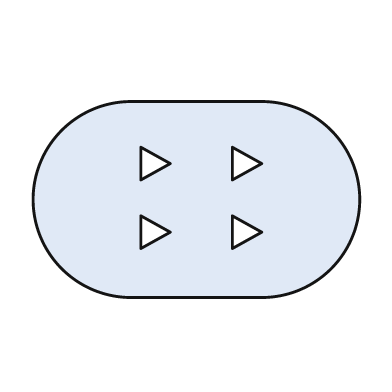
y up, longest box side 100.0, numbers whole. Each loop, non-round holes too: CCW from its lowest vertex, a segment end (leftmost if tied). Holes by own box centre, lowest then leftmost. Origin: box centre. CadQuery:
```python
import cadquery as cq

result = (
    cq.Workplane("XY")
    .moveTo(-20.0, -30.0)
    .lineTo(20.0, -30.0)
    .threePointArc((50.0, 0.0), (20.0, 30.0))
    .lineTo(-20.0, 30.0)
    .threePointArc((-50.0, 0.0), (-20.0, -30.0))
    .close()
    .moveTo(-17.0, -15.0)
    .lineTo(-8.0, -10.0)
    .lineTo(-17.0, -5.0)
    .close()
    .moveTo(11.0, -15.0)
    .lineTo(20.0, -10.0)
    .lineTo(11.0, -5.0)
    .close()
    .moveTo(-17.0, 6.0)
    .lineTo(-8.0, 11.0)
    .lineTo(-17.0, 16.0)
    .close()
    .moveTo(11.0, 6.0)
    .lineTo(20.0, 11.0)
    .lineTo(11.0, 16.0)
    .close()
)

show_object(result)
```